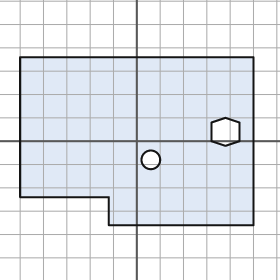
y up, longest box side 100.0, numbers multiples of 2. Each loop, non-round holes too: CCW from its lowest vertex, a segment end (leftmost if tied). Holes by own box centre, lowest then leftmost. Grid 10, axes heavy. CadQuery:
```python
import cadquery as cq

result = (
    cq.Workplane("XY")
    .moveTo(-12.0, -36.0)
    .lineTo(50.0, -36.0)
    .lineTo(50.0, 36.0)
    .lineTo(-50.0, 36.0)
    .lineTo(-50.0, -24.0)
    .lineTo(-12.0, -24.0)
    .close()
    .moveTo(6.0, -8.0)
    .circle(4.0)
    .moveTo(38.0, -2.0)
    .lineTo(44.0, 0.0)
    .lineTo(44.0, 8.0)
    .lineTo(38.0, 10.0)
    .lineTo(32.0, 8.0)
    .lineTo(32.0, 0.0)
    .close()
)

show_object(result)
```